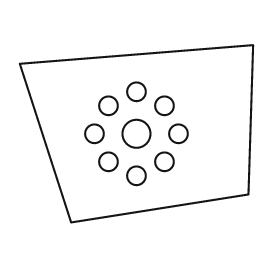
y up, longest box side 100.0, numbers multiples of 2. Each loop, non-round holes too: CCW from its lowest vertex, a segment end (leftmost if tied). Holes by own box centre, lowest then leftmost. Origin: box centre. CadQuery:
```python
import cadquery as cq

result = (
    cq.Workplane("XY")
    .moveTo(-28.0, -38.0)
    .lineTo(48.0, -26.0)
    .lineTo(50.0, 38.0)
    .lineTo(-50.0, 30.0)
    .close()
    .moveTo(0.0, -18.0)
    .circle(4.0)
    .moveTo(-12.0, -12.0)
    .circle(4.0)
    .moveTo(12.0, -12.0)
    .circle(4.0)
    .moveTo(-18.0, 0.0)
    .circle(4.0)
    .moveTo(0.0, 0.0)
    .circle(6.0)
    .moveTo(18.0, 0.0)
    .circle(4.0)
    .moveTo(-12.0, 12.0)
    .circle(4.0)
    .moveTo(12.0, 12.0)
    .circle(4.0)
    .moveTo(0.0, 18.0)
    .circle(4.0)
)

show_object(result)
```